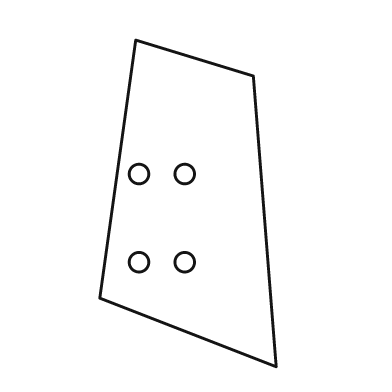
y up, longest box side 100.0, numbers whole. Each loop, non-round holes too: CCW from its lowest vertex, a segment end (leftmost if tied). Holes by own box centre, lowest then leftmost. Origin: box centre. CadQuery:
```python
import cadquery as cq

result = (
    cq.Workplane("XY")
    .moveTo(27.0, -50.0)
    .lineTo(20.0, 39.0)
    .lineTo(-16.0, 50.0)
    .lineTo(-27.0, -29.0)
    .close()
    .moveTo(-15.0, -18.0)
    .circle(3.0)
    .moveTo(-1.0, -18.0)
    .circle(3.0)
    .moveTo(-15.0, 9.0)
    .circle(3.0)
    .moveTo(-1.0, 9.0)
    .circle(3.0)
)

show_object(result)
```